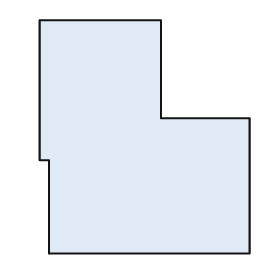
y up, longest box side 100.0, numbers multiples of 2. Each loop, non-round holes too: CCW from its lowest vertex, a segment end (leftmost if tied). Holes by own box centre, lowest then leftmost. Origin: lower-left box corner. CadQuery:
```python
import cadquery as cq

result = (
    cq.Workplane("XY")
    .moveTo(4.0, 0.0)
    .lineTo(90.0, 0.0)
    .lineTo(90.0, 58.0)
    .lineTo(52.0, 58.0)
    .lineTo(52.0, 100.0)
    .lineTo(0.0, 100.0)
    .lineTo(0.0, 40.0)
    .lineTo(4.0, 40.0)
    .close()
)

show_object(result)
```